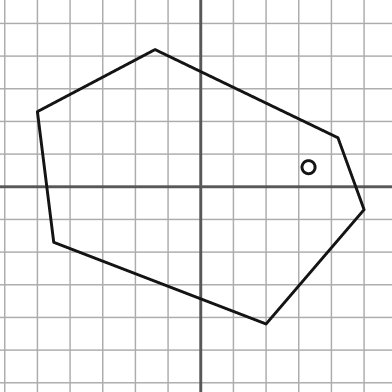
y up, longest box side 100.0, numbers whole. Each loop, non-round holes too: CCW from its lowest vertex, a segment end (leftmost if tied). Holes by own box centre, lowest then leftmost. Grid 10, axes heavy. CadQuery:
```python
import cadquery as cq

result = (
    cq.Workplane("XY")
    .moveTo(20.0, -42.0)
    .lineTo(50.0, -7.0)
    .lineTo(42.0, 15.0)
    .lineTo(-14.0, 42.0)
    .lineTo(-50.0, 23.0)
    .lineTo(-45.0, -17.0)
    .close()
    .moveTo(33.0, 6.0)
    .circle(2.0)
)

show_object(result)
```